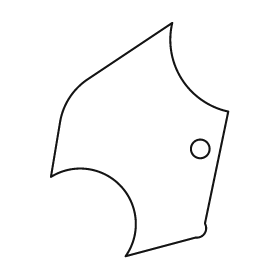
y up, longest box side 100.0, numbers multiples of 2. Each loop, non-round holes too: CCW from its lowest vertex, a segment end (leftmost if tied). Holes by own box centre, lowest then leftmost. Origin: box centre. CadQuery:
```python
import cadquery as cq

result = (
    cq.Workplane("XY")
    .moveTo(-6.0, -50.0)
    .lineTo(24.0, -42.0)
    .threePointArc((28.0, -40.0), (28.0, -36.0))
    .lineTo(38.0, 12.0)
    .threePointArc((18.0, 26.0), (14.0, 50.0))
    .lineTo(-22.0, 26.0)
    .threePointArc((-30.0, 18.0), (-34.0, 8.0))
    .lineTo(-38.0, -16.0)
    .threePointArc((-8.0, -20.0), (-6.0, -50.0))
    .close()
    .moveTo(26.0, -4.0)
    .circle(4.0)
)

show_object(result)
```